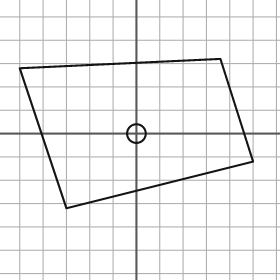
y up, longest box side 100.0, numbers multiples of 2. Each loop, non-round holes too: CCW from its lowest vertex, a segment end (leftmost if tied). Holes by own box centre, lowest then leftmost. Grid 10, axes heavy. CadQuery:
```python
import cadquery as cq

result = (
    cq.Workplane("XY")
    .moveTo(-30.0, -32.0)
    .lineTo(50.0, -12.0)
    .lineTo(36.0, 32.0)
    .lineTo(-50.0, 28.0)
    .close()
    .moveTo(0.0, 0.0)
    .circle(4.0)
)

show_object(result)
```